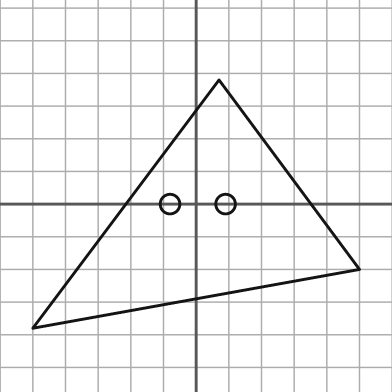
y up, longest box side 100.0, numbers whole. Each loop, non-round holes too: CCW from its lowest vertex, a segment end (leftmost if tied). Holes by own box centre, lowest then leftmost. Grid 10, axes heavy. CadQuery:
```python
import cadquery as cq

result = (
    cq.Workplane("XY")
    .moveTo(-50.0, -38.0)
    .lineTo(50.0, -20.0)
    .lineTo(7.0, 38.0)
    .close()
    .moveTo(-8.0, 0.0)
    .circle(3.0)
    .moveTo(9.0, 0.0)
    .circle(3.0)
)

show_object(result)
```